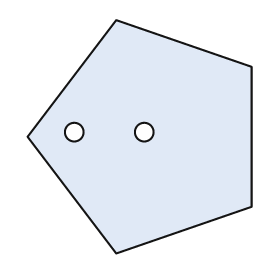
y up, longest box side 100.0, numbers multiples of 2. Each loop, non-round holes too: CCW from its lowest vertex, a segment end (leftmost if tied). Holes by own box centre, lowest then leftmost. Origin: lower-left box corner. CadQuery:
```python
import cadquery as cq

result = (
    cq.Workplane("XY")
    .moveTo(38.0, 0.0)
    .lineTo(96.0, 20.0)
    .lineTo(96.0, 80.0)
    .lineTo(38.0, 100.0)
    .lineTo(0.0, 50.0)
    .close()
    .moveTo(20.0, 52.0)
    .circle(4.0)
    .moveTo(50.0, 52.0)
    .circle(4.0)
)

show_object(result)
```